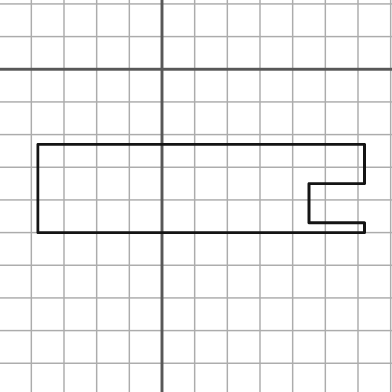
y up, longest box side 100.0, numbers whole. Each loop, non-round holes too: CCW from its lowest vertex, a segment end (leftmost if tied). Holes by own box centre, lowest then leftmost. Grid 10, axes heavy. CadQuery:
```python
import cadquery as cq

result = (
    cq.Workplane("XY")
    .moveTo(-38.0, -50.0)
    .lineTo(62.0, -50.0)
    .lineTo(62.0, -47.0)
    .lineTo(45.0, -47.0)
    .lineTo(45.0, -35.0)
    .lineTo(62.0, -35.0)
    .lineTo(62.0, -23.0)
    .lineTo(-38.0, -23.0)
    .close()
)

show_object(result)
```